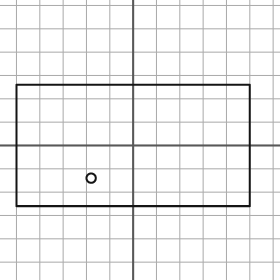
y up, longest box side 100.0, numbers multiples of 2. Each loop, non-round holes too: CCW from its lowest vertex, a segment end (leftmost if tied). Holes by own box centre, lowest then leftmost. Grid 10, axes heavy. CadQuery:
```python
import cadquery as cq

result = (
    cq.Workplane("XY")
    .moveTo(-50.0, -26.0)
    .lineTo(50.0, -26.0)
    .lineTo(50.0, 26.0)
    .lineTo(-50.0, 26.0)
    .close()
    .moveTo(-18.0, -14.0)
    .circle(2.0)
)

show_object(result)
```